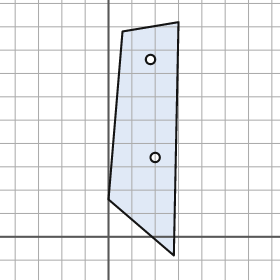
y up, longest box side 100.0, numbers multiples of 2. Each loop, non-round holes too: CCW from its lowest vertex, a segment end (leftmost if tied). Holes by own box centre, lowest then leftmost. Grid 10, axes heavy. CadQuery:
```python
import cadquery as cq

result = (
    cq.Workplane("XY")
    .moveTo(28.0, -8.0)
    .lineTo(30.0, 92.0)
    .lineTo(6.0, 88.0)
    .lineTo(0.0, 16.0)
    .close()
    .moveTo(20.0, 34.0)
    .circle(2.0)
    .moveTo(18.0, 76.0)
    .circle(2.0)
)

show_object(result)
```